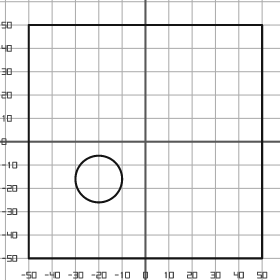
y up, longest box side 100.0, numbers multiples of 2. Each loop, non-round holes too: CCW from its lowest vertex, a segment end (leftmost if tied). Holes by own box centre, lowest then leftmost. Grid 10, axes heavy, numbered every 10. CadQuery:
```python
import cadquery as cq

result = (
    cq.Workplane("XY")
    .moveTo(-50.0, -50.0)
    .lineTo(50.0, -50.0)
    .lineTo(50.0, 50.0)
    .lineTo(-50.0, 50.0)
    .close()
    .moveTo(-20.0, -16.0)
    .circle(10.0)
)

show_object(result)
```